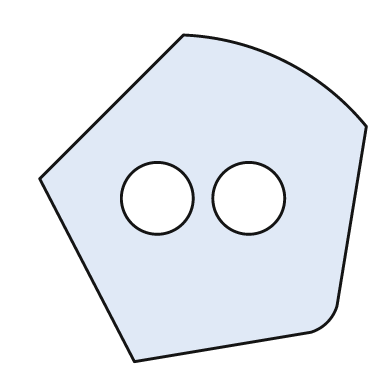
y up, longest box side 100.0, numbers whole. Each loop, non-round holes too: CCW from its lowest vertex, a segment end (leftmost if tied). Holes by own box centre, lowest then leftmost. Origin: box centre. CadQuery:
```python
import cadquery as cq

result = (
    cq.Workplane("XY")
    .moveTo(-21.0, -50.0)
    .lineTo(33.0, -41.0)
    .threePointArc((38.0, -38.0), (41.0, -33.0))
    .lineTo(50.0, 22.0)
    .threePointArc((25.0, 42.0), (-6.0, 50.0))
    .lineTo(-50.0, 6.0)
    .close()
    .moveTo(-14.0, 0.0)
    .circle(11.0)
    .moveTo(14.0, 0.0)
    .circle(11.0)
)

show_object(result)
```